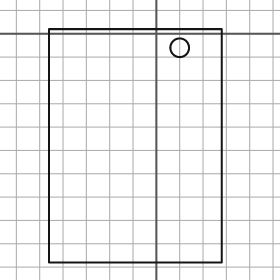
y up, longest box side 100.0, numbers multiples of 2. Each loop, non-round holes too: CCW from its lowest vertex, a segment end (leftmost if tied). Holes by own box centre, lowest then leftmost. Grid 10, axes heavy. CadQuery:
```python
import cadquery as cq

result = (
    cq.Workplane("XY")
    .moveTo(-46.0, -98.0)
    .lineTo(28.0, -98.0)
    .lineTo(28.0, 2.0)
    .lineTo(-46.0, 2.0)
    .close()
    .moveTo(10.0, -6.0)
    .circle(4.0)
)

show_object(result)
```